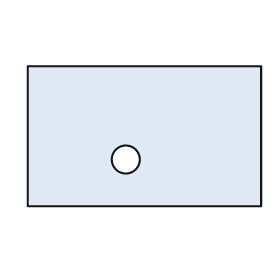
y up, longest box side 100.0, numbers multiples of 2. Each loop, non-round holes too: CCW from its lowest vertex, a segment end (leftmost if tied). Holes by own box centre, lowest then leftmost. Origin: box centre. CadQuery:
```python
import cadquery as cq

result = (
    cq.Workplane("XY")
    .moveTo(-50.0, -30.0)
    .lineTo(50.0, -30.0)
    .lineTo(50.0, 30.0)
    .lineTo(-50.0, 30.0)
    .close()
    .moveTo(-8.0, -10.0)
    .circle(6.0)
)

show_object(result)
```